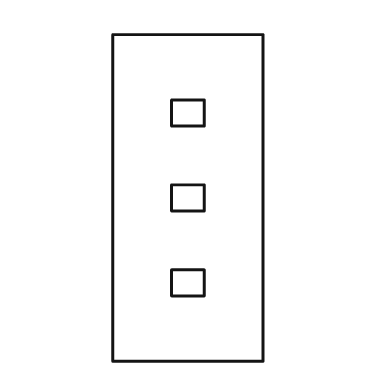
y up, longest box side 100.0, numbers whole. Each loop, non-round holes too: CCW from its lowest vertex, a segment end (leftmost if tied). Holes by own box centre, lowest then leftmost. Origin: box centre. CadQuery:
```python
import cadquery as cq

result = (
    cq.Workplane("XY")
    .moveTo(-23.0, -50.0)
    .lineTo(23.0, -50.0)
    .lineTo(23.0, 50.0)
    .lineTo(-23.0, 50.0)
    .close()
    .moveTo(-5.0, -30.0)
    .lineTo(5.0, -30.0)
    .lineTo(5.0, -22.0)
    .lineTo(-5.0, -22.0)
    .close()
    .moveTo(-5.0, -4.0)
    .lineTo(5.0, -4.0)
    .lineTo(5.0, 4.0)
    .lineTo(-5.0, 4.0)
    .close()
    .moveTo(-5.0, 22.0)
    .lineTo(5.0, 22.0)
    .lineTo(5.0, 30.0)
    .lineTo(-5.0, 30.0)
    .close()
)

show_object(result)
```